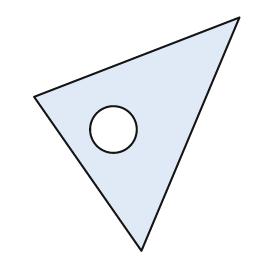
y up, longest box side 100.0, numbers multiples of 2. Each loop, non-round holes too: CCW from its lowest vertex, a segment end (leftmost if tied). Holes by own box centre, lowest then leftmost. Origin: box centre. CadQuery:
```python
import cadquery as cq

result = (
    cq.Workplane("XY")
    .moveTo(2.0, -50.0)
    .lineTo(44.0, 50.0)
    .lineTo(-44.0, 16.0)
    .close()
    .moveTo(-10.0, 2.0)
    .circle(10.0)
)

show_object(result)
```